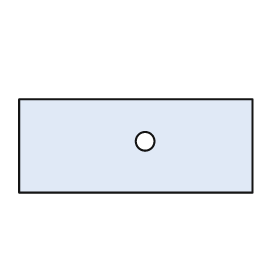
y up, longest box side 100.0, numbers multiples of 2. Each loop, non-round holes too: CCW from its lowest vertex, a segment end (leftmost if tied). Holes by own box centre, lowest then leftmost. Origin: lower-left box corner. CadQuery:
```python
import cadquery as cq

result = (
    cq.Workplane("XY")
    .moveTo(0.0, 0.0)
    .lineTo(100.0, 0.0)
    .lineTo(100.0, 40.0)
    .lineTo(0.0, 40.0)
    .close()
    .moveTo(54.0, 22.0)
    .circle(4.0)
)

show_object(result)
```